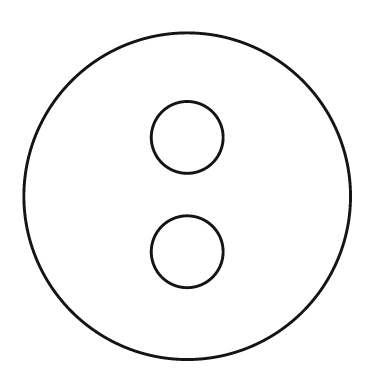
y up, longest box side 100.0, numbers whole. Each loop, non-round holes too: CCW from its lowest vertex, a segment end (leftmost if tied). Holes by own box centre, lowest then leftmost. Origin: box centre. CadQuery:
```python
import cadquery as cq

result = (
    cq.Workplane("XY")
    .moveTo(0.0, 0.0)
    .circle(50.0)
    .moveTo(0.0, -17.0)
    .circle(11.0)
    .moveTo(0.0, 18.0)
    .circle(11.0)
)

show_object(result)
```